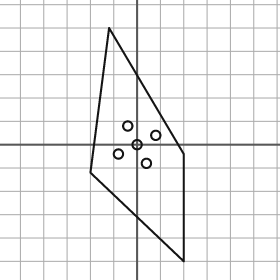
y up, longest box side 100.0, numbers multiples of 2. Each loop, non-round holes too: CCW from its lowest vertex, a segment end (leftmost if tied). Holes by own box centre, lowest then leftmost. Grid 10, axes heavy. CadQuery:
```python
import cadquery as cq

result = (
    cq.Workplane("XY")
    .moveTo(20.0, -50.0)
    .lineTo(20.0, -4.0)
    .lineTo(-12.0, 50.0)
    .lineTo(-20.0, -12.0)
    .close()
    .moveTo(4.0, -8.0)
    .circle(2.0)
    .moveTo(-8.0, -4.0)
    .circle(2.0)
    .moveTo(0.0, 0.0)
    .circle(2.0)
    .moveTo(8.0, 4.0)
    .circle(2.0)
    .moveTo(-4.0, 8.0)
    .circle(2.0)
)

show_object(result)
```